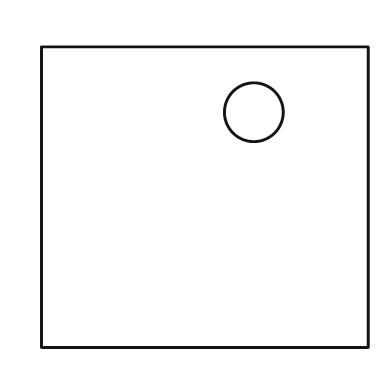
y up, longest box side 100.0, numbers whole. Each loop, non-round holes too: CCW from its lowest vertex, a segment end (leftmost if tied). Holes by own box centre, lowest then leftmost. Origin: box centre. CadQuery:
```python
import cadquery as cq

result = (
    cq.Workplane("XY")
    .moveTo(-50.0, -46.0)
    .lineTo(50.0, -46.0)
    .lineTo(50.0, 46.0)
    .lineTo(-50.0, 46.0)
    .close()
    .moveTo(15.0, 26.0)
    .circle(9.0)
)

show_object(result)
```